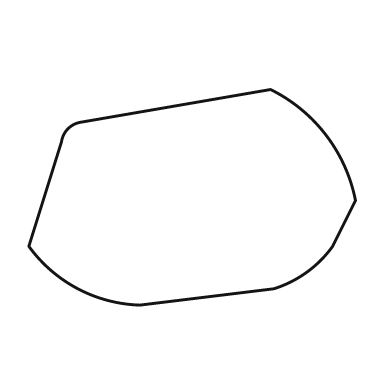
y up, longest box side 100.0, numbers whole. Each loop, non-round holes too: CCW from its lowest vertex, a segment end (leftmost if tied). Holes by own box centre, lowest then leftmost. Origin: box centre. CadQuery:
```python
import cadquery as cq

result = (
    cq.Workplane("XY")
    .moveTo(-16.0, -33.0)
    .lineTo(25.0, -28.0)
    .threePointArc((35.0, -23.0), (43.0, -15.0))
    .lineTo(50.0, -1.0)
    .threePointArc((41.0, 19.0), (24.0, 33.0))
    .lineTo(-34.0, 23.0)
    .threePointArc((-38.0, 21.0), (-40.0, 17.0))
    .lineTo(-50.0, -15.0)
    .threePointArc((-35.0, -28.0), (-16.0, -33.0))
    .close()
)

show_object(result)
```